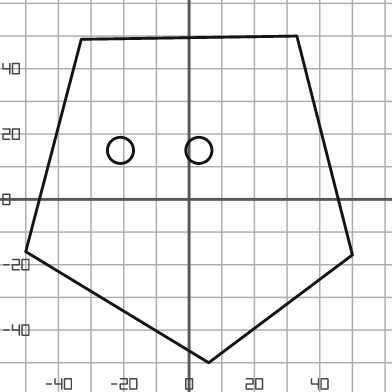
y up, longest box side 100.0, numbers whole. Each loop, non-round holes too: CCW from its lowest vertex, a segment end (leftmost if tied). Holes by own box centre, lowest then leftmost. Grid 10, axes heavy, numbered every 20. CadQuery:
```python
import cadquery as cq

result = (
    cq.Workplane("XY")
    .moveTo(6.0, -50.0)
    .lineTo(50.0, -17.0)
    .lineTo(33.0, 50.0)
    .lineTo(-33.0, 49.0)
    .lineTo(-50.0, -16.0)
    .close()
    .moveTo(-21.0, 15.0)
    .circle(4.0)
    .moveTo(3.0, 15.0)
    .circle(4.0)
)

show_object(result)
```